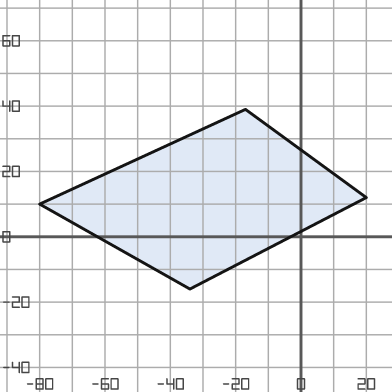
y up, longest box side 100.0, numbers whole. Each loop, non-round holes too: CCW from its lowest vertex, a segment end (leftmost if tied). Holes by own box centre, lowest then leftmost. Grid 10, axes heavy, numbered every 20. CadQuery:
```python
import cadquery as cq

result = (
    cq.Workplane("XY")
    .moveTo(-34.0, -16.0)
    .lineTo(20.0, 12.0)
    .lineTo(-17.0, 39.0)
    .lineTo(-80.0, 10.0)
    .close()
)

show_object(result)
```